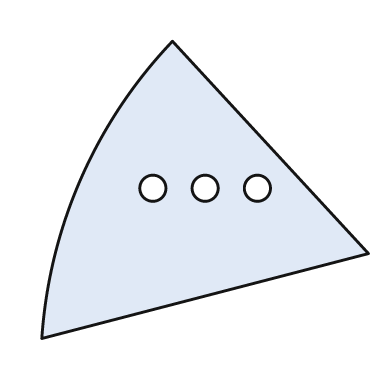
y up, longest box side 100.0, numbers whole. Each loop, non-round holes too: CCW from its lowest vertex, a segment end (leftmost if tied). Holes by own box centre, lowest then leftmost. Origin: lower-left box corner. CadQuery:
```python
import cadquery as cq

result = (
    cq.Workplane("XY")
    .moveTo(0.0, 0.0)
    .lineTo(100.0, 26.0)
    .lineTo(40.0, 91.0)
    .threePointArc((12.0, 49.0), (0.0, 0.0))
    .close()
    .moveTo(34.0, 46.0)
    .circle(4.0)
    .moveTo(50.0, 46.0)
    .circle(4.0)
    .moveTo(66.0, 46.0)
    .circle(4.0)
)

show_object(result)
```